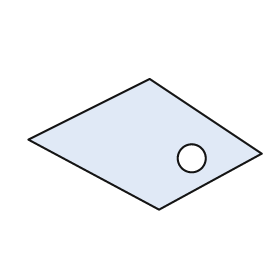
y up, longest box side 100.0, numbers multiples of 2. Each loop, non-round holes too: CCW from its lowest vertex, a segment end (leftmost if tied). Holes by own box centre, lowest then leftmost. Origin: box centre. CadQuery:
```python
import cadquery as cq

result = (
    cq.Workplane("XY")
    .moveTo(6.0, -28.0)
    .lineTo(50.0, -4.0)
    .lineTo(2.0, 28.0)
    .lineTo(-50.0, 2.0)
    .close()
    .moveTo(20.0, -6.0)
    .circle(6.0)
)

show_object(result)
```